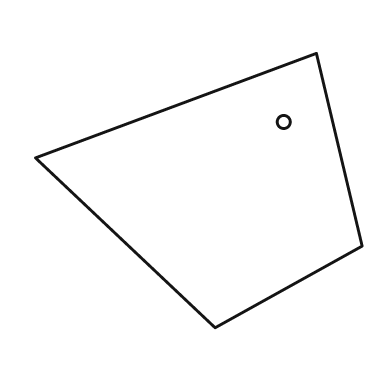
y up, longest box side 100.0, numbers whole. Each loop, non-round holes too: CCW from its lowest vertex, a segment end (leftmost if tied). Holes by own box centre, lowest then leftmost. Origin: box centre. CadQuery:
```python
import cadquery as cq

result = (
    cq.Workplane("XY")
    .moveTo(5.0, -42.0)
    .lineTo(50.0, -17.0)
    .lineTo(36.0, 42.0)
    .lineTo(-50.0, 10.0)
    .close()
    .moveTo(26.0, 21.0)
    .circle(2.0)
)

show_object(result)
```